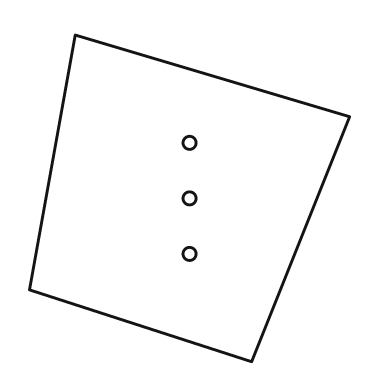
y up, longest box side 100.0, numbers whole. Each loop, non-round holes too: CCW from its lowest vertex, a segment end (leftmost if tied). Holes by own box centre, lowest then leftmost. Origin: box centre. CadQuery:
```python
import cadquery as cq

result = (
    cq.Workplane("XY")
    .moveTo(19.0, -50.0)
    .lineTo(49.0, 25.0)
    .lineTo(-35.0, 50.0)
    .lineTo(-49.0, -28.0)
    .close()
    .moveTo(0.0, -17.0)
    .circle(2.0)
    .moveTo(0.0, 0.0)
    .circle(2.0)
    .moveTo(0.0, 17.0)
    .circle(2.0)
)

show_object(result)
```